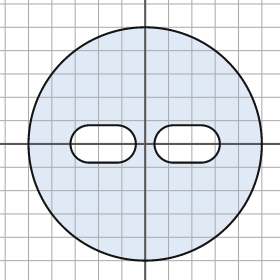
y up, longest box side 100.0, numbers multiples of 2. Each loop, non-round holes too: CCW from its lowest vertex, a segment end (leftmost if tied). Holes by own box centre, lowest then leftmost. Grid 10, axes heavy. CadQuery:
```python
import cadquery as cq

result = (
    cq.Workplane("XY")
    .moveTo(0.0, 0.0)
    .circle(50.0)
    .moveTo(-24.0, -8.0)
    .lineTo(-12.0, -8.0)
    .threePointArc((-4.0, 0.0), (-12.0, 8.0))
    .lineTo(-24.0, 8.0)
    .threePointArc((-32.0, 0.0), (-24.0, -8.0))
    .close()
    .moveTo(12.0, -8.0)
    .lineTo(24.0, -8.0)
    .threePointArc((32.0, 0.0), (24.0, 8.0))
    .lineTo(12.0, 8.0)
    .threePointArc((4.0, 0.0), (12.0, -8.0))
    .close()
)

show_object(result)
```